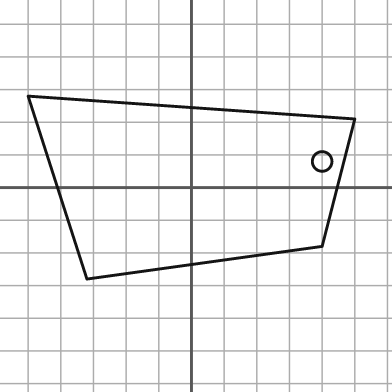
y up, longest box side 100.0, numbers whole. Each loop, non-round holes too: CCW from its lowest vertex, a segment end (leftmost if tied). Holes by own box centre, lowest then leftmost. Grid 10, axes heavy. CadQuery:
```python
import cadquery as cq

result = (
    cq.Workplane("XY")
    .moveTo(-32.0, -28.0)
    .lineTo(40.0, -18.0)
    .lineTo(50.0, 21.0)
    .lineTo(-50.0, 28.0)
    .close()
    .moveTo(40.0, 8.0)
    .circle(3.0)
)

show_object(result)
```